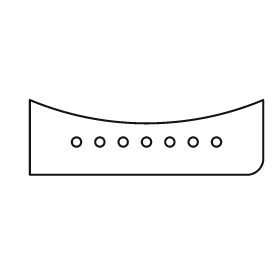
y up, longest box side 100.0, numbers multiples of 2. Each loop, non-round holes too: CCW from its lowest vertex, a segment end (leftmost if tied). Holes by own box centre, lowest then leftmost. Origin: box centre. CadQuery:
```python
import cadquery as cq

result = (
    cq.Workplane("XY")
    .moveTo(-50.0, -16.0)
    .lineTo(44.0, -16.0)
    .threePointArc((48.0, -14.0), (50.0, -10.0))
    .lineTo(50.0, 16.0)
    .threePointArc((0.0, 6.0), (-50.0, 16.0))
    .close()
    .moveTo(-30.0, -2.0)
    .circle(2.0)
    .moveTo(-20.0, -2.0)
    .circle(2.0)
    .moveTo(-10.0, -2.0)
    .circle(2.0)
    .moveTo(0.0, -2.0)
    .circle(2.0)
    .moveTo(10.0, -2.0)
    .circle(2.0)
    .moveTo(20.0, -2.0)
    .circle(2.0)
    .moveTo(30.0, -2.0)
    .circle(2.0)
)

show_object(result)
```